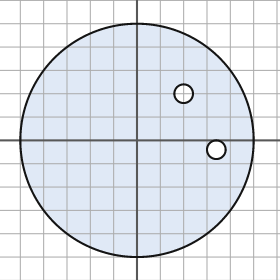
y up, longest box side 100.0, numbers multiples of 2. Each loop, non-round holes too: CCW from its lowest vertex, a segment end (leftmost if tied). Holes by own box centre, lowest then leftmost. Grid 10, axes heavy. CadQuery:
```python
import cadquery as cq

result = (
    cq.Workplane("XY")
    .moveTo(0.0, 0.0)
    .circle(50.0)
    .moveTo(34.0, -4.0)
    .circle(4.0)
    .moveTo(20.0, 20.0)
    .circle(4.0)
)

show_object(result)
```